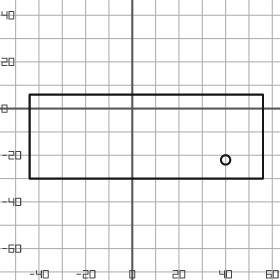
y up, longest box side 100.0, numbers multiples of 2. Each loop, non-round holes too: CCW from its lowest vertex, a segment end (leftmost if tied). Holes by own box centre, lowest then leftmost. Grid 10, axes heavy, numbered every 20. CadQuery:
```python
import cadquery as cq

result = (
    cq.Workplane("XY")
    .moveTo(-44.0, -30.0)
    .lineTo(56.0, -30.0)
    .lineTo(56.0, 6.0)
    .lineTo(-44.0, 6.0)
    .close()
    .moveTo(40.0, -22.0)
    .circle(2.0)
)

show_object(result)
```